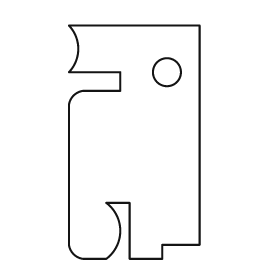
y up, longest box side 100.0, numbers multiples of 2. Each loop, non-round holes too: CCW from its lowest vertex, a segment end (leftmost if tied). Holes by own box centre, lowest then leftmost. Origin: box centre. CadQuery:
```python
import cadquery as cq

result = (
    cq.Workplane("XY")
    .moveTo(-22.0, -50.0)
    .lineTo(-12.0, -50.0)
    .threePointArc((-6.0, -38.0), (-12.0, -26.0))
    .lineTo(-2.0, -26.0)
    .lineTo(-2.0, -50.0)
    .lineTo(12.0, -50.0)
    .lineTo(12.0, -44.0)
    .lineTo(28.0, -44.0)
    .lineTo(28.0, 50.0)
    .lineTo(-28.0, 50.0)
    .threePointArc((-24.0, 40.0), (-28.0, 30.0))
    .lineTo(-6.0, 30.0)
    .lineTo(-6.0, 22.0)
    .lineTo(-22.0, 22.0)
    .threePointArc((-26.0, 20.0), (-28.0, 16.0))
    .lineTo(-28.0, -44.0)
    .threePointArc((-26.0, -48.0), (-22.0, -50.0))
    .close()
    .moveTo(14.0, 30.0)
    .circle(6.0)
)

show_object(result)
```